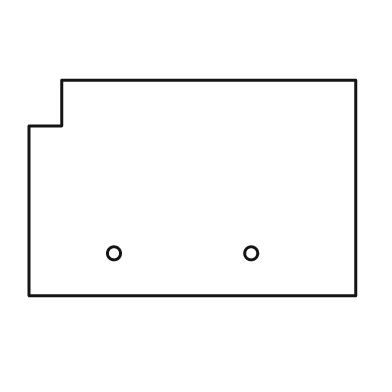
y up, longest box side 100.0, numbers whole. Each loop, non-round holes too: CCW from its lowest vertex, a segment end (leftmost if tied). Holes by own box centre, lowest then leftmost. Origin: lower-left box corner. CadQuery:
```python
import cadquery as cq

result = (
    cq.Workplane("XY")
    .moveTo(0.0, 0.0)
    .lineTo(100.0, 0.0)
    .lineTo(100.0, 66.0)
    .lineTo(10.0, 66.0)
    .lineTo(10.0, 52.0)
    .lineTo(0.0, 52.0)
    .close()
    .moveTo(26.0, 13.0)
    .circle(2.0)
    .moveTo(68.0, 13.0)
    .circle(2.0)
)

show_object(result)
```